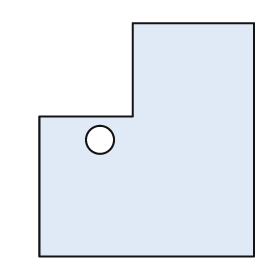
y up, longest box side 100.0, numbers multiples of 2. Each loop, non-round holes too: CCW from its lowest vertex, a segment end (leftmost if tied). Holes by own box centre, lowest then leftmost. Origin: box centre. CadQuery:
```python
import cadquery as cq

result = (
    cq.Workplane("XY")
    .moveTo(-46.0, -50.0)
    .lineTo(46.0, -50.0)
    .lineTo(46.0, 50.0)
    .lineTo(-6.0, 50.0)
    .lineTo(-6.0, 10.0)
    .lineTo(-46.0, 10.0)
    .close()
    .moveTo(-20.0, 0.0)
    .circle(6.0)
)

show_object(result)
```